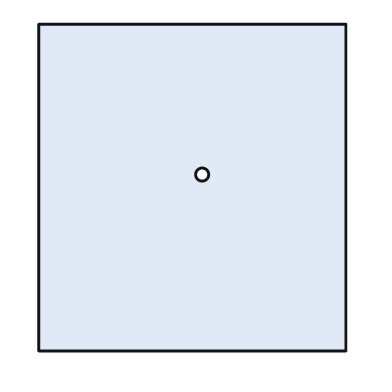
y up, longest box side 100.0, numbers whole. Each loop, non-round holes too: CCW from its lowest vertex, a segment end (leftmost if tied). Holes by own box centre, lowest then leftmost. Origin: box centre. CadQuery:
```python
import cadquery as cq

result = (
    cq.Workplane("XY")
    .moveTo(-47.0, -50.0)
    .lineTo(47.0, -50.0)
    .lineTo(47.0, 50.0)
    .lineTo(-47.0, 50.0)
    .close()
    .moveTo(3.0, 4.0)
    .circle(2.0)
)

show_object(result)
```